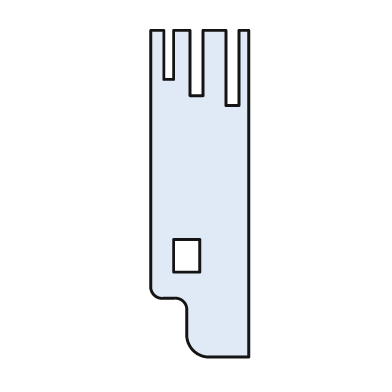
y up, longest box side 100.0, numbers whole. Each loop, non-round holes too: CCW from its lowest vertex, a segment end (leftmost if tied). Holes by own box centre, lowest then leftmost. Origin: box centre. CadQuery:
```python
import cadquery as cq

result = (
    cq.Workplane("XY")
    .moveTo(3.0, -50.0)
    .lineTo(15.0, -50.0)
    .lineTo(15.0, 50.0)
    .lineTo(12.0, 50.0)
    .lineTo(12.0, 27.0)
    .lineTo(8.0, 27.0)
    .lineTo(8.0, 50.0)
    .lineTo(1.0, 50.0)
    .lineTo(1.0, 30.0)
    .lineTo(-3.0, 30.0)
    .lineTo(-3.0, 50.0)
    .lineTo(-8.0, 50.0)
    .lineTo(-8.0, 35.0)
    .lineTo(-11.0, 35.0)
    .lineTo(-11.0, 50.0)
    .lineTo(-15.0, 50.0)
    .lineTo(-15.0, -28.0)
    .threePointArc((-14.0, -31.0), (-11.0, -32.0))
    .lineTo(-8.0, -32.0)
    .threePointArc((-5.0, -33.0), (-4.0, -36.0))
    .lineTo(-4.0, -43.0)
    .threePointArc((-2.0, -48.0), (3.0, -50.0))
    .close()
    .moveTo(-8.0, -24.0)
    .lineTo(0.0, -24.0)
    .lineTo(0.0, -14.0)
    .lineTo(-8.0, -14.0)
    .close()
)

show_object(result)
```